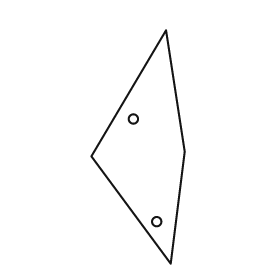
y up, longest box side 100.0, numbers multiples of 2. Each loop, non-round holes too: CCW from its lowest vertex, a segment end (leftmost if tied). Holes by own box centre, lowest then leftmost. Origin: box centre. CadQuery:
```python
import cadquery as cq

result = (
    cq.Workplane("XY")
    .moveTo(14.0, -50.0)
    .lineTo(20.0, -2.0)
    .lineTo(12.0, 50.0)
    .lineTo(-20.0, -4.0)
    .close()
    .moveTo(8.0, -32.0)
    .circle(2.0)
    .moveTo(-2.0, 12.0)
    .circle(2.0)
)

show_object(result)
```